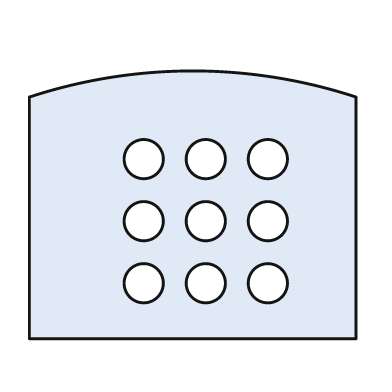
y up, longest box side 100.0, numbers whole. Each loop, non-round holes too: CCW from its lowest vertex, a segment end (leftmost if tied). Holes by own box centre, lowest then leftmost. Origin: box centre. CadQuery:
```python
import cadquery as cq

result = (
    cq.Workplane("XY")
    .moveTo(-50.0, -41.0)
    .lineTo(50.0, -41.0)
    .lineTo(50.0, 33.0)
    .threePointArc((0.0, 41.0), (-50.0, 33.0))
    .close()
    .moveTo(-15.0, -24.0)
    .circle(6.0)
    .moveTo(4.0, -24.0)
    .circle(6.0)
    .moveTo(23.0, -24.0)
    .circle(6.0)
    .moveTo(-15.0, -5.0)
    .circle(6.0)
    .moveTo(4.0, -5.0)
    .circle(6.0)
    .moveTo(23.0, -5.0)
    .circle(6.0)
    .moveTo(-15.0, 14.0)
    .circle(6.0)
    .moveTo(4.0, 14.0)
    .circle(6.0)
    .moveTo(23.0, 14.0)
    .circle(6.0)
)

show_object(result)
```